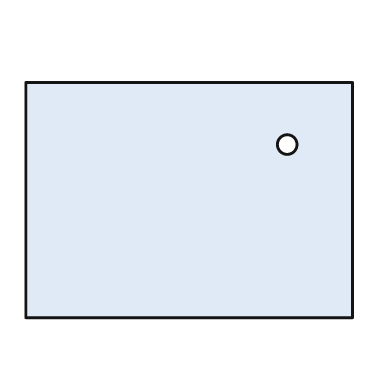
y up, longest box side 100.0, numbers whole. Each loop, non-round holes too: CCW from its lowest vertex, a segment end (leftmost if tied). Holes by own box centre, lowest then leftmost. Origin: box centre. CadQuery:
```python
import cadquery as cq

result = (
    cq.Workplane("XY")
    .moveTo(-50.0, -36.0)
    .lineTo(50.0, -36.0)
    .lineTo(50.0, 36.0)
    .lineTo(-50.0, 36.0)
    .close()
    .moveTo(30.0, 17.0)
    .circle(3.0)
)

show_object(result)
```